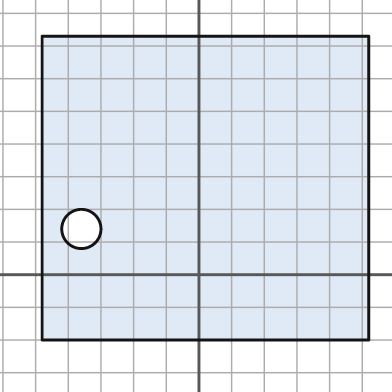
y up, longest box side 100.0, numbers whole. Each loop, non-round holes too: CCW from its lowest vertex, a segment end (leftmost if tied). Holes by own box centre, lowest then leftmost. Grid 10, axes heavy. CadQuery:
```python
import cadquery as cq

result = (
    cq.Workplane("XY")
    .moveTo(-48.0, -20.0)
    .lineTo(52.0, -20.0)
    .lineTo(52.0, 73.0)
    .lineTo(-48.0, 73.0)
    .close()
    .moveTo(-36.0, 14.0)
    .circle(6.0)
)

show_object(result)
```